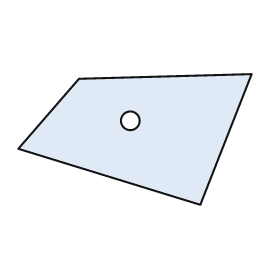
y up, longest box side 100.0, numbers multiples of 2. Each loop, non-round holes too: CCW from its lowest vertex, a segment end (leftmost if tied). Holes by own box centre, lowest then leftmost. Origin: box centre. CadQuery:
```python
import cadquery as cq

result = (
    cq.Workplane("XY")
    .moveTo(28.0, -28.0)
    .lineTo(50.0, 28.0)
    .lineTo(-24.0, 26.0)
    .lineTo(-50.0, -4.0)
    .close()
    .moveTo(-2.0, 8.0)
    .circle(4.0)
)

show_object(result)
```